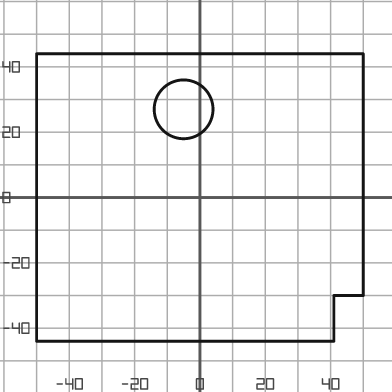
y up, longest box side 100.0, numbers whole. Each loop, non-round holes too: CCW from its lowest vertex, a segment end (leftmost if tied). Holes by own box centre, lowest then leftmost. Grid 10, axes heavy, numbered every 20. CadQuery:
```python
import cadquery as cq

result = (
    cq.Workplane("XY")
    .moveTo(-50.0, -44.0)
    .lineTo(41.0, -44.0)
    .lineTo(41.0, -30.0)
    .lineTo(50.0, -30.0)
    .lineTo(50.0, 44.0)
    .lineTo(-50.0, 44.0)
    .close()
    .moveTo(-5.0, 27.0)
    .circle(9.0)
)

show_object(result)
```